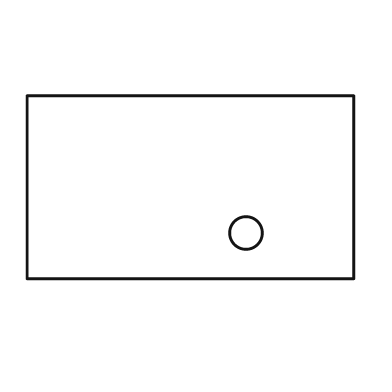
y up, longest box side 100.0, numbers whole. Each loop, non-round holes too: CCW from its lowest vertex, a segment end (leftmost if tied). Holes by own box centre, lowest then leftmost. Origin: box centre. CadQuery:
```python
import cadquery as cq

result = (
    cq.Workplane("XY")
    .moveTo(-50.0, -28.0)
    .lineTo(50.0, -28.0)
    .lineTo(50.0, 28.0)
    .lineTo(-50.0, 28.0)
    .close()
    .moveTo(17.0, -14.0)
    .circle(5.0)
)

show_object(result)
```